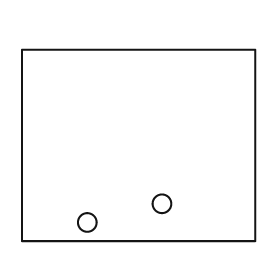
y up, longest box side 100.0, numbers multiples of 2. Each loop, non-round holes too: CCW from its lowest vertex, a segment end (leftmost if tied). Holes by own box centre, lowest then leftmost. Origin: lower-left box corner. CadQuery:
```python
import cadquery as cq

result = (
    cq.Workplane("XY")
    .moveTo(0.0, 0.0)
    .lineTo(100.0, 0.0)
    .lineTo(100.0, 82.0)
    .lineTo(0.0, 82.0)
    .close()
    .moveTo(28.0, 8.0)
    .circle(4.0)
    .moveTo(60.0, 16.0)
    .circle(4.0)
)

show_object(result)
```